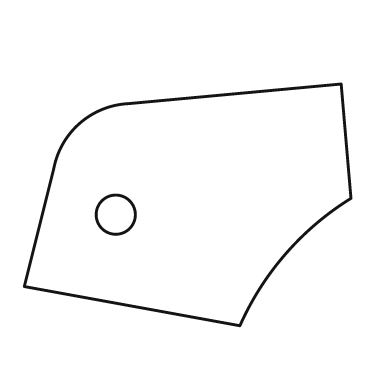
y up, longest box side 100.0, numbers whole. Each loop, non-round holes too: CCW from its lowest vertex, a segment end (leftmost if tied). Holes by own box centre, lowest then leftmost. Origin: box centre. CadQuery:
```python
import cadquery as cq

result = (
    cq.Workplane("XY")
    .moveTo(16.0, -37.0)
    .threePointArc((30.0, -15.0), (50.0, 2.0))
    .lineTo(47.0, 37.0)
    .lineTo(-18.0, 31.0)
    .threePointArc((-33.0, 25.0), (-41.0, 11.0))
    .lineTo(-50.0, -25.0)
    .close()
    .moveTo(-22.0, -3.0)
    .circle(6.0)
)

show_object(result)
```